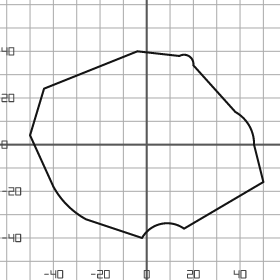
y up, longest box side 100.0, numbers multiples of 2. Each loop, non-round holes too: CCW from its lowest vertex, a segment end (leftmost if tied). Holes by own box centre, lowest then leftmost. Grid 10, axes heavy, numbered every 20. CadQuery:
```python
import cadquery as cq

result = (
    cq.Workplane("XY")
    .moveTo(-2.0, -40.0)
    .threePointArc((6.0, -34.0), (16.0, -36.0))
    .lineTo(50.0, -16.0)
    .lineTo(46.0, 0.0)
    .threePointArc((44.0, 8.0), (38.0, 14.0))
    .lineTo(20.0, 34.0)
    .threePointArc((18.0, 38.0), (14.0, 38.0))
    .lineTo(-4.0, 40.0)
    .lineTo(-44.0, 24.0)
    .lineTo(-50.0, 4.0)
    .lineTo(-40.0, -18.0)
    .threePointArc((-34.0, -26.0), (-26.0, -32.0))
    .close()
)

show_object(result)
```